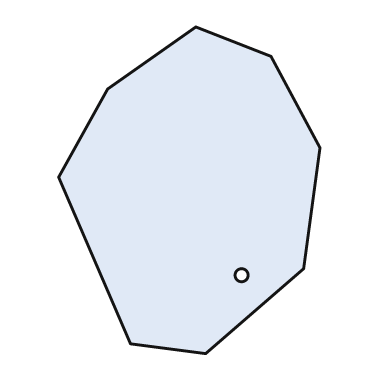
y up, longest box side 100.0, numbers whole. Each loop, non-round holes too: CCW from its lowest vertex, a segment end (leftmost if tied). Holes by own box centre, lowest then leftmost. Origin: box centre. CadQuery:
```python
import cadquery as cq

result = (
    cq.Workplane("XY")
    .moveTo(5.0, -50.0)
    .lineTo(35.0, -24.0)
    .lineTo(40.0, 13.0)
    .lineTo(25.0, 41.0)
    .lineTo(2.0, 50.0)
    .lineTo(-25.0, 31.0)
    .lineTo(-40.0, 4.0)
    .lineTo(-18.0, -47.0)
    .close()
    .moveTo(16.0, -26.0)
    .circle(2.0)
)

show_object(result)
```